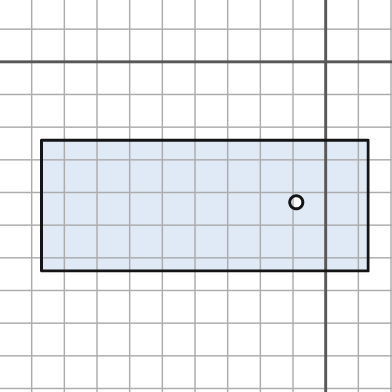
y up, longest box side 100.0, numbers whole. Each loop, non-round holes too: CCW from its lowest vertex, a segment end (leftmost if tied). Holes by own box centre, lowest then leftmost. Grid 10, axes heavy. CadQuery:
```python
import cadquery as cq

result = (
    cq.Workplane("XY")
    .moveTo(-87.0, -64.0)
    .lineTo(13.0, -64.0)
    .lineTo(13.0, -24.0)
    .lineTo(-87.0, -24.0)
    .close()
    .moveTo(-9.0, -43.0)
    .circle(2.0)
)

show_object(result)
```